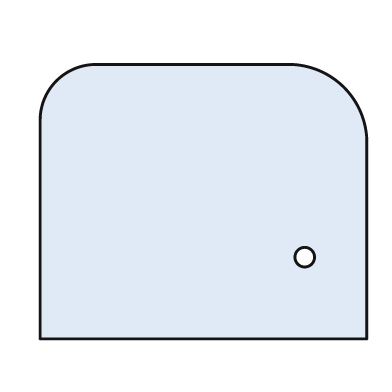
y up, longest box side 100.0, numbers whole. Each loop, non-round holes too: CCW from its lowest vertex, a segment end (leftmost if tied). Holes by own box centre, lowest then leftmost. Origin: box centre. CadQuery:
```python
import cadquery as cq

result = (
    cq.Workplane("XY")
    .moveTo(-50.0, -42.0)
    .lineTo(50.0, -42.0)
    .lineTo(50.0, 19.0)
    .threePointArc((43.0, 35.0), (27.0, 42.0))
    .lineTo(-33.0, 42.0)
    .threePointArc((-45.0, 37.0), (-50.0, 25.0))
    .close()
    .moveTo(31.0, -17.0)
    .circle(3.0)
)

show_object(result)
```